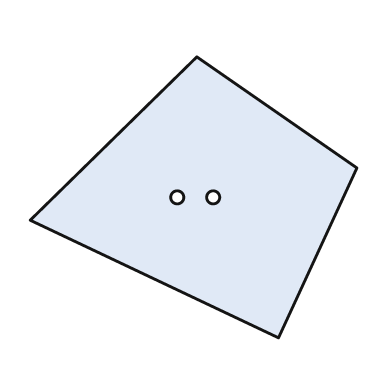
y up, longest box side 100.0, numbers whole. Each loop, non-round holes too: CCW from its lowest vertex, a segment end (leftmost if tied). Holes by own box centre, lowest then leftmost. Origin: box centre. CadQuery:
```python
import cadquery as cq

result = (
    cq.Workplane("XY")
    .moveTo(26.0, -43.0)
    .lineTo(50.0, 9.0)
    .lineTo(1.0, 43.0)
    .lineTo(-50.0, -7.0)
    .close()
    .moveTo(-5.0, 0.0)
    .circle(2.0)
    .moveTo(6.0, 0.0)
    .circle(2.0)
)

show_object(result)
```